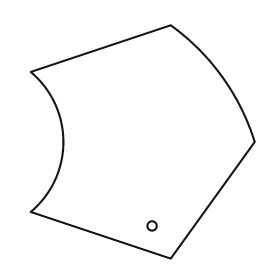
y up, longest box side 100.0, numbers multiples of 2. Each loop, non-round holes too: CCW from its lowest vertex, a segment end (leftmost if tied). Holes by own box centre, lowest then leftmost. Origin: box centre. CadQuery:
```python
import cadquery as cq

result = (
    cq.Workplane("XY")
    .moveTo(12.0, -50.0)
    .lineTo(48.0, 0.0)
    .threePointArc((34.0, 28.0), (12.0, 50.0))
    .lineTo(-48.0, 30.0)
    .threePointArc((-34.0, 0.0), (-48.0, -30.0))
    .close()
    .moveTo(4.0, -36.0)
    .circle(2.0)
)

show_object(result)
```